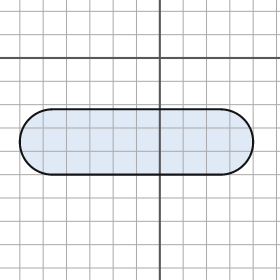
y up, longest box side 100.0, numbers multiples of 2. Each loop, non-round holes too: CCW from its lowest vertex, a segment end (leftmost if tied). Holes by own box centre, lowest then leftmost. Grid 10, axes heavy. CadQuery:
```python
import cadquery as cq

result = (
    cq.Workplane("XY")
    .moveTo(-46.0, -50.0)
    .lineTo(26.0, -50.0)
    .threePointArc((40.0, -36.0), (26.0, -22.0))
    .lineTo(-46.0, -22.0)
    .threePointArc((-60.0, -36.0), (-46.0, -50.0))
    .close()
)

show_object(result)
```